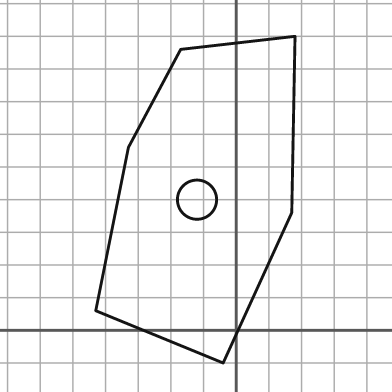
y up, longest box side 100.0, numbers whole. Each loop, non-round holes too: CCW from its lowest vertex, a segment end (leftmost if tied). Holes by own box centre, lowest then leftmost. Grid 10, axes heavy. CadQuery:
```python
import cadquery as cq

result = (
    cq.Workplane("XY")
    .moveTo(-4.0, -10.0)
    .lineTo(17.0, 36.0)
    .lineTo(18.0, 90.0)
    .lineTo(-17.0, 86.0)
    .lineTo(-33.0, 56.0)
    .lineTo(-43.0, 6.0)
    .close()
    .moveTo(-12.0, 40.0)
    .circle(6.0)
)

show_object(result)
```